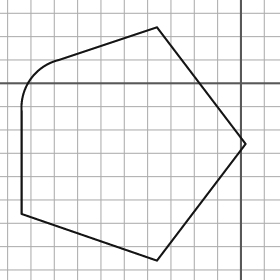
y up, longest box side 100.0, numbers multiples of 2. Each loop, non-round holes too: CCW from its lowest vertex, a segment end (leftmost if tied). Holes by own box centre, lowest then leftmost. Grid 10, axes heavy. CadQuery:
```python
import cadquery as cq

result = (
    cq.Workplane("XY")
    .moveTo(-36.0, -76.0)
    .lineTo(2.0, -26.0)
    .lineTo(-36.0, 24.0)
    .lineTo(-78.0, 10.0)
    .threePointArc((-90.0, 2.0), (-94.0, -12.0))
    .lineTo(-94.0, -56.0)
    .close()
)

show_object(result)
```